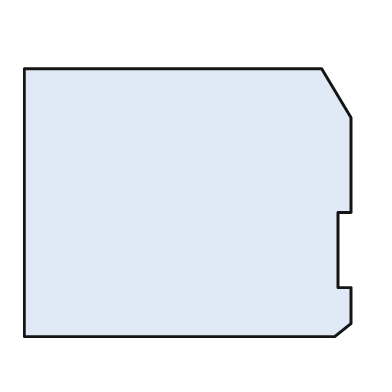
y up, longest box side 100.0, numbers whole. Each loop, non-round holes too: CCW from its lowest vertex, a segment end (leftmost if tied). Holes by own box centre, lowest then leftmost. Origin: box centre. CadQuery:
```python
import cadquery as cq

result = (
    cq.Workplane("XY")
    .moveTo(-50.0, -41.0)
    .lineTo(45.0, -41.0)
    .lineTo(50.0, -37.0)
    .lineTo(50.0, -26.0)
    .lineTo(46.0, -26.0)
    .lineTo(46.0, -3.0)
    .lineTo(50.0, -3.0)
    .lineTo(50.0, 26.0)
    .lineTo(41.0, 41.0)
    .lineTo(-50.0, 41.0)
    .close()
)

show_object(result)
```